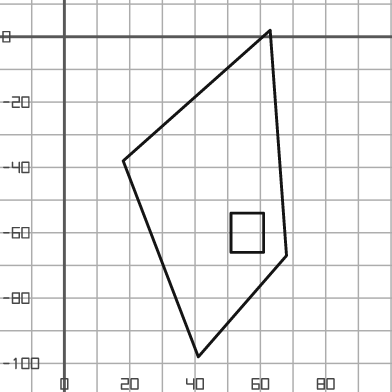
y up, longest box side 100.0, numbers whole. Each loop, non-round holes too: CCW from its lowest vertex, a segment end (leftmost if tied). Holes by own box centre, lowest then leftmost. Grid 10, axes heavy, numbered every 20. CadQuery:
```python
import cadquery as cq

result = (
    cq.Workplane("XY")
    .moveTo(41.0, -98.0)
    .lineTo(68.0, -67.0)
    .lineTo(63.0, 2.0)
    .lineTo(18.0, -38.0)
    .close()
    .moveTo(51.0, -66.0)
    .lineTo(61.0, -66.0)
    .lineTo(61.0, -54.0)
    .lineTo(51.0, -54.0)
    .close()
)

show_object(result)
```